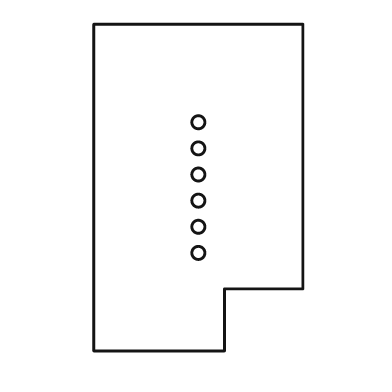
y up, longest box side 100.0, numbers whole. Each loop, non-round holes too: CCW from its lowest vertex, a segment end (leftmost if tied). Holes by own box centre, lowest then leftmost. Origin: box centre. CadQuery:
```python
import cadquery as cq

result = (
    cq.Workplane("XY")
    .moveTo(-32.0, -50.0)
    .lineTo(8.0, -50.0)
    .lineTo(8.0, -31.0)
    .lineTo(32.0, -31.0)
    .lineTo(32.0, 50.0)
    .lineTo(-32.0, 50.0)
    .close()
    .moveTo(0.0, -20.0)
    .circle(2.0)
    .moveTo(0.0, -12.0)
    .circle(2.0)
    .moveTo(0.0, -4.0)
    .circle(2.0)
    .moveTo(0.0, 4.0)
    .circle(2.0)
    .moveTo(0.0, 12.0)
    .circle(2.0)
    .moveTo(0.0, 20.0)
    .circle(2.0)
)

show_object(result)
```